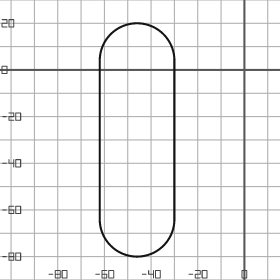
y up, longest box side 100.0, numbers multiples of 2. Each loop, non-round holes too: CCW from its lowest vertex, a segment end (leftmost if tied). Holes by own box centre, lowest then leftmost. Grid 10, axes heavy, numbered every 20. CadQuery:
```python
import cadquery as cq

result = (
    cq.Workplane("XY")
    .moveTo(-62.0, -64.0)
    .threePointArc((-46.0, -80.0), (-30.0, -64.0))
    .lineTo(-30.0, 4.0)
    .threePointArc((-46.0, 20.0), (-62.0, 4.0))
    .close()
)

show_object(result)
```